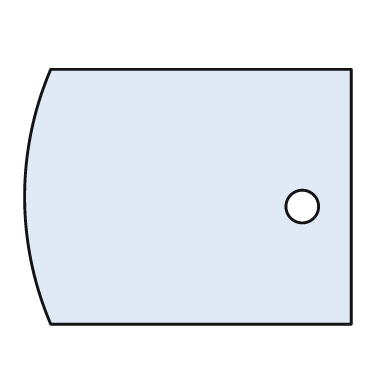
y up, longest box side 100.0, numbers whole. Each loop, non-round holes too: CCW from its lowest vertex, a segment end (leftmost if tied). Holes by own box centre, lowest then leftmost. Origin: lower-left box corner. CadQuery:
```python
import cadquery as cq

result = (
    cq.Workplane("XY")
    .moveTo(8.0, 0.0)
    .lineTo(100.0, 0.0)
    .lineTo(100.0, 78.0)
    .lineTo(8.0, 78.0)
    .threePointArc((0.0, 39.0), (8.0, 0.0))
    .close()
    .moveTo(85.0, 36.0)
    .circle(5.0)
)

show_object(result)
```